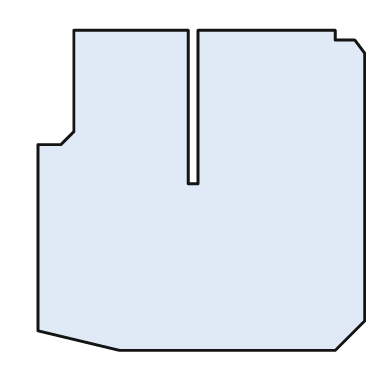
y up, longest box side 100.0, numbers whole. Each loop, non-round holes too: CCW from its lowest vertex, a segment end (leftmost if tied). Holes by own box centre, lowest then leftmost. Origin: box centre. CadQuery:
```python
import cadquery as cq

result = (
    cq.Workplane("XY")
    .moveTo(-25.0, -49.0)
    .lineTo(41.0, -49.0)
    .lineTo(50.0, -40.0)
    .lineTo(50.0, 42.0)
    .lineTo(47.0, 46.0)
    .lineTo(41.0, 46.0)
    .lineTo(41.0, 49.0)
    .lineTo(-1.0, 49.0)
    .lineTo(-1.0, 2.0)
    .lineTo(-4.0, 2.0)
    .lineTo(-4.0, 49.0)
    .lineTo(-39.0, 49.0)
    .lineTo(-39.0, 18.0)
    .lineTo(-43.0, 14.0)
    .lineTo(-50.0, 14.0)
    .lineTo(-50.0, -43.0)
    .close()
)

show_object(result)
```